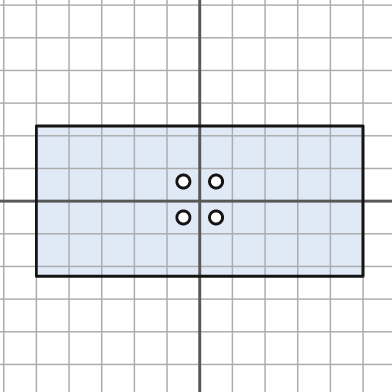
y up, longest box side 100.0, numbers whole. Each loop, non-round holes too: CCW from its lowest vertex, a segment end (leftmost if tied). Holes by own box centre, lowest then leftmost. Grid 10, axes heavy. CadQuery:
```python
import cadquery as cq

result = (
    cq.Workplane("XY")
    .moveTo(-50.0, -23.0)
    .lineTo(50.0, -23.0)
    .lineTo(50.0, 23.0)
    .lineTo(-50.0, 23.0)
    .close()
    .moveTo(-5.0, -5.0)
    .circle(2.0)
    .moveTo(5.0, -5.0)
    .circle(2.0)
    .moveTo(-5.0, 6.0)
    .circle(2.0)
    .moveTo(5.0, 6.0)
    .circle(2.0)
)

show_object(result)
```